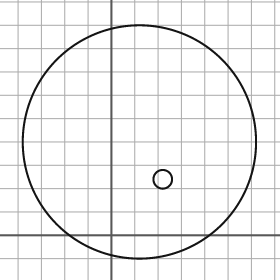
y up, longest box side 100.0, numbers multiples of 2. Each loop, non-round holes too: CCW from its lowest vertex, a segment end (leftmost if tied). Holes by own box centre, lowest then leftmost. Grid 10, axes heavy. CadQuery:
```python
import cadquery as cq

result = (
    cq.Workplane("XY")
    .moveTo(12.0, 40.0)
    .circle(50.0)
    .moveTo(22.0, 24.0)
    .circle(4.0)
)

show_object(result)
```